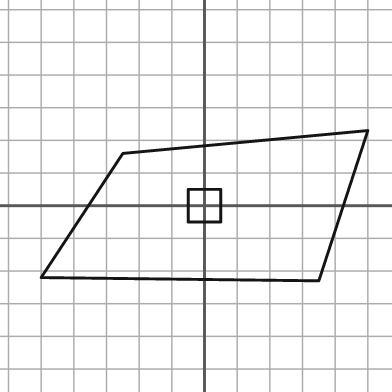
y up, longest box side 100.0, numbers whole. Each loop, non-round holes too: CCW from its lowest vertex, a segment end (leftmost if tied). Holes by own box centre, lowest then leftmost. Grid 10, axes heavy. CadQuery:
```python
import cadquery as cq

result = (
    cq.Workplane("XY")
    .moveTo(35.0, -23.0)
    .lineTo(50.0, 23.0)
    .lineTo(-25.0, 16.0)
    .lineTo(-50.0, -22.0)
    .close()
    .moveTo(-5.0, -5.0)
    .lineTo(5.0, -5.0)
    .lineTo(5.0, 5.0)
    .lineTo(-5.0, 5.0)
    .close()
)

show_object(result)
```